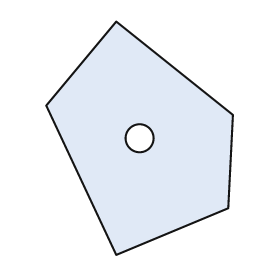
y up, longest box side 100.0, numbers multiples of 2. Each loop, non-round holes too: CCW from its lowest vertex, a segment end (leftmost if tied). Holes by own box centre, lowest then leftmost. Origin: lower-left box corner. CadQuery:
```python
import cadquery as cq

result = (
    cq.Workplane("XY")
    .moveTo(30.0, 0.0)
    .lineTo(78.0, 20.0)
    .lineTo(80.0, 60.0)
    .lineTo(30.0, 100.0)
    .lineTo(0.0, 64.0)
    .close()
    .moveTo(40.0, 50.0)
    .circle(6.0)
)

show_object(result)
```